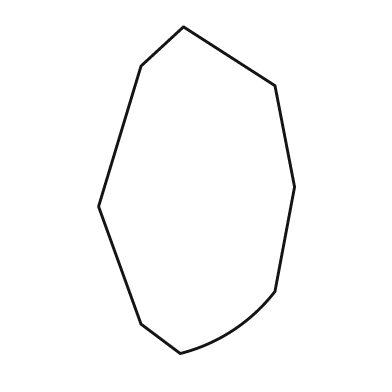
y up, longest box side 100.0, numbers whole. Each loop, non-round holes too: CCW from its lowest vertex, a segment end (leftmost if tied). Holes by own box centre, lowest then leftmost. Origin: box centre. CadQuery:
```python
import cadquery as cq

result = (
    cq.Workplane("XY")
    .moveTo(-5.0, -50.0)
    .threePointArc((11.0, -43.0), (24.0, -31.0))
    .lineTo(30.0, 1.0)
    .lineTo(24.0, 32.0)
    .lineTo(-4.0, 50.0)
    .lineTo(-17.0, 38.0)
    .lineTo(-30.0, -5.0)
    .lineTo(-17.0, -41.0)
    .close()
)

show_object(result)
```